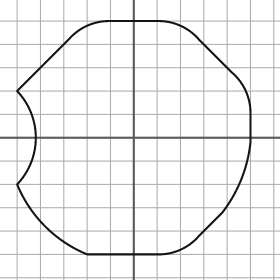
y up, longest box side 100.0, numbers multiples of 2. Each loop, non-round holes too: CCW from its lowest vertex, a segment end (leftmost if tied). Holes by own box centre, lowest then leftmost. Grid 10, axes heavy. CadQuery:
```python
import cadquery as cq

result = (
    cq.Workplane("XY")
    .moveTo(-20.0, -50.0)
    .lineTo(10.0, -50.0)
    .threePointArc((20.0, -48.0), (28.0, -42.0))
    .lineTo(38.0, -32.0)
    .threePointArc((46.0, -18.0), (50.0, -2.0))
    .lineTo(50.0, 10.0)
    .threePointArc((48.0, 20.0), (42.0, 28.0))
    .lineTo(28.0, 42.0)
    .threePointArc((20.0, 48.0), (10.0, 50.0))
    .lineTo(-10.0, 50.0)
    .threePointArc((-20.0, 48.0), (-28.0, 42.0))
    .lineTo(-50.0, 20.0)
    .threePointArc((-42.0, 0.0), (-50.0, -20.0))
    .threePointArc((-38.0, -38.0), (-20.0, -50.0))
    .close()
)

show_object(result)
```